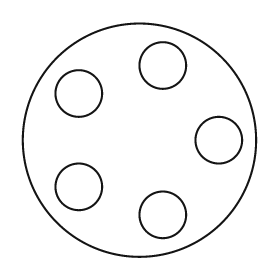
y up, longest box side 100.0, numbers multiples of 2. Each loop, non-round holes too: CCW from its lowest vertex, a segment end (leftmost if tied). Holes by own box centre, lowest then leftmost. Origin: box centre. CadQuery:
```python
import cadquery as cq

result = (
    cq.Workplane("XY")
    .moveTo(0.0, 0.0)
    .circle(50.0)
    .moveTo(10.0, -32.0)
    .circle(10.0)
    .moveTo(-26.0, -20.0)
    .circle(10.0)
    .moveTo(34.0, 0.0)
    .circle(10.0)
    .moveTo(-26.0, 20.0)
    .circle(10.0)
    .moveTo(10.0, 32.0)
    .circle(10.0)
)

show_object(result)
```